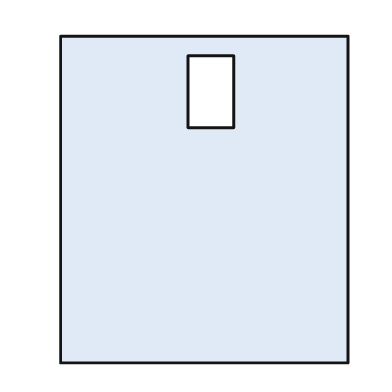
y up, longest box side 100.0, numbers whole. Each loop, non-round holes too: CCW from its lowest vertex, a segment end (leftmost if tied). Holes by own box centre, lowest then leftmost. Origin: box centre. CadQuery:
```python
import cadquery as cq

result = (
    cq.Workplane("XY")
    .moveTo(-44.0, -50.0)
    .lineTo(44.0, -50.0)
    .lineTo(44.0, 50.0)
    .lineTo(-44.0, 50.0)
    .close()
    .moveTo(-5.0, 22.0)
    .lineTo(9.0, 22.0)
    .lineTo(9.0, 44.0)
    .lineTo(-5.0, 44.0)
    .close()
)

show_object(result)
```